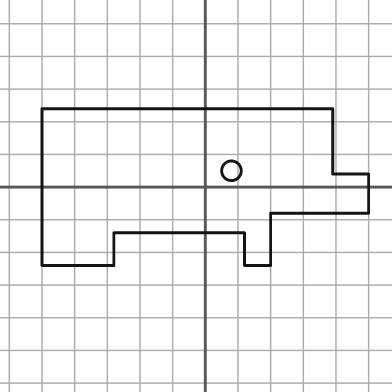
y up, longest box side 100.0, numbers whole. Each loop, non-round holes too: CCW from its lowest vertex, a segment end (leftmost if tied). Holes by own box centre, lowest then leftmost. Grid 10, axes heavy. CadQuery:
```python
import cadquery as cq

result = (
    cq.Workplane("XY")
    .moveTo(-50.0, -24.0)
    .lineTo(-28.0, -24.0)
    .lineTo(-28.0, -14.0)
    .lineTo(12.0, -14.0)
    .lineTo(12.0, -24.0)
    .lineTo(20.0, -24.0)
    .lineTo(20.0, -8.0)
    .lineTo(50.0, -8.0)
    .lineTo(50.0, 4.0)
    .lineTo(39.0, 4.0)
    .lineTo(39.0, 24.0)
    .lineTo(-50.0, 24.0)
    .close()
    .moveTo(8.0, 5.0)
    .circle(3.0)
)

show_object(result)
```